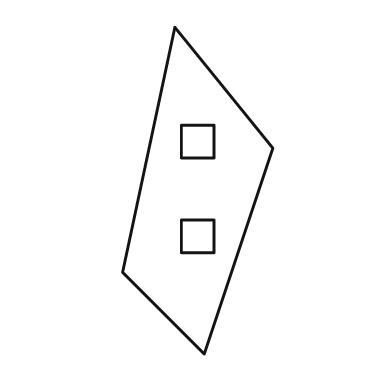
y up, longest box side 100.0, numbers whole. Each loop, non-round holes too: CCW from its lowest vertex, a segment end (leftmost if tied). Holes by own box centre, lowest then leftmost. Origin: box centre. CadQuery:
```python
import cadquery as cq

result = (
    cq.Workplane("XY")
    .moveTo(2.0, -50.0)
    .lineTo(23.0, 13.0)
    .lineTo(-7.0, 50.0)
    .lineTo(-23.0, -25.0)
    .close()
    .moveTo(-5.0, -19.0)
    .lineTo(5.0, -19.0)
    .lineTo(5.0, -9.0)
    .lineTo(-5.0, -9.0)
    .close()
    .moveTo(-5.0, 10.0)
    .lineTo(5.0, 10.0)
    .lineTo(5.0, 20.0)
    .lineTo(-5.0, 20.0)
    .close()
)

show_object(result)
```